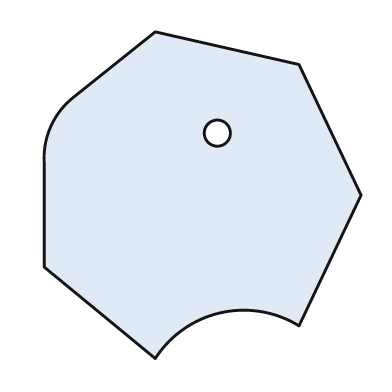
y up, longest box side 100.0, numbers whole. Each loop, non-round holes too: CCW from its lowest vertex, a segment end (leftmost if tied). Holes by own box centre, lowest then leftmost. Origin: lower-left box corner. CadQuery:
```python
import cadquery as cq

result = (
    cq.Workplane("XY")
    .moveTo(34.0, 0.0)
    .threePointArc((54.0, 14.0), (78.0, 10.0))
    .lineTo(97.0, 50.0)
    .lineTo(78.0, 90.0)
    .lineTo(34.0, 100.0)
    .lineTo(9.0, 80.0)
    .threePointArc((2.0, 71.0), (0.0, 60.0))
    .lineTo(0.0, 28.0)
    .close()
    .moveTo(53.0, 69.0)
    .circle(4.0)
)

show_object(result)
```